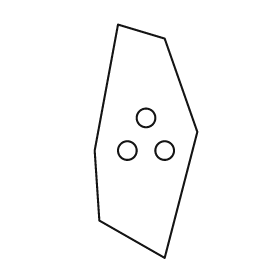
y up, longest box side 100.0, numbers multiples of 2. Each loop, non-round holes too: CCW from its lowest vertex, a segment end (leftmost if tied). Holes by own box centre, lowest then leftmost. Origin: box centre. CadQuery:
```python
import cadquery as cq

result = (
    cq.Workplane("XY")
    .moveTo(8.0, -50.0)
    .lineTo(22.0, 4.0)
    .lineTo(8.0, 44.0)
    .lineTo(-12.0, 50.0)
    .lineTo(-22.0, -4.0)
    .lineTo(-20.0, -34.0)
    .close()
    .moveTo(-8.0, -4.0)
    .circle(4.0)
    .moveTo(8.0, -4.0)
    .circle(4.0)
    .moveTo(0.0, 10.0)
    .circle(4.0)
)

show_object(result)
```